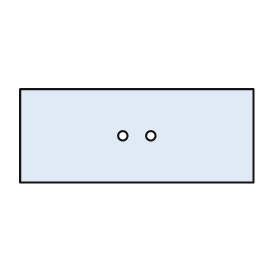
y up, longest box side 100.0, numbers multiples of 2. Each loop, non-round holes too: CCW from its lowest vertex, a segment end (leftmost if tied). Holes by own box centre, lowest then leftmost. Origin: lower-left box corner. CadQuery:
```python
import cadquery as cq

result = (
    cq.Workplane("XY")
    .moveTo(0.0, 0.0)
    .lineTo(100.0, 0.0)
    .lineTo(100.0, 40.0)
    .lineTo(0.0, 40.0)
    .close()
    .moveTo(44.0, 20.0)
    .circle(2.0)
    .moveTo(56.0, 20.0)
    .circle(2.0)
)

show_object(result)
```